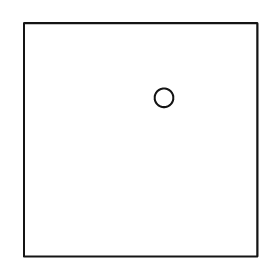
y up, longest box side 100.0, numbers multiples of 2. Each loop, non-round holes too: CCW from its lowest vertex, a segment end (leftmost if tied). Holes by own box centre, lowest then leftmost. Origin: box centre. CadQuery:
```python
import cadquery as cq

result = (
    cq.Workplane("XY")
    .moveTo(-50.0, -50.0)
    .lineTo(50.0, -50.0)
    .lineTo(50.0, 50.0)
    .lineTo(-50.0, 50.0)
    .close()
    .moveTo(10.0, 18.0)
    .circle(4.0)
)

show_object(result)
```